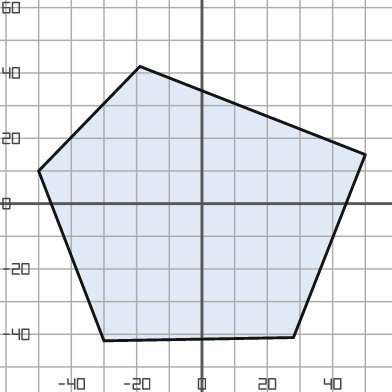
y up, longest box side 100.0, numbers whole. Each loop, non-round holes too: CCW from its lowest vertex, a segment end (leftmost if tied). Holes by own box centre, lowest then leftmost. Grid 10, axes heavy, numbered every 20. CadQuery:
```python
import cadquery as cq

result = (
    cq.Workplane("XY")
    .moveTo(-30.0, -42.0)
    .lineTo(28.0, -41.0)
    .lineTo(50.0, 15.0)
    .lineTo(-19.0, 42.0)
    .lineTo(-50.0, 10.0)
    .close()
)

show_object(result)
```